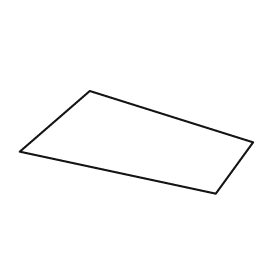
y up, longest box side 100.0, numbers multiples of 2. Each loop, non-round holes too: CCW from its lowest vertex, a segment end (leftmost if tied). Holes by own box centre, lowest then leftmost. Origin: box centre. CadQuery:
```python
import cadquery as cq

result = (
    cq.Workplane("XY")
    .moveTo(34.0, -22.0)
    .lineTo(50.0, 0.0)
    .lineTo(-20.0, 22.0)
    .lineTo(-50.0, -4.0)
    .close()
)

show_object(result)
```